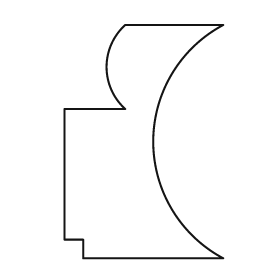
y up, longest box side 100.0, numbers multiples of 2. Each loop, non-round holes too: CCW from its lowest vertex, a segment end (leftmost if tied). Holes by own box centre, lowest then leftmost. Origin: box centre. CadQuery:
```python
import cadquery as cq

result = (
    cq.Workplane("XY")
    .moveTo(-26.0, -50.0)
    .lineTo(34.0, -50.0)
    .threePointArc((4.0, 0.0), (34.0, 50.0))
    .lineTo(-8.0, 50.0)
    .threePointArc((-16.0, 32.0), (-8.0, 14.0))
    .lineTo(-34.0, 14.0)
    .lineTo(-34.0, -42.0)
    .lineTo(-26.0, -42.0)
    .close()
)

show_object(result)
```